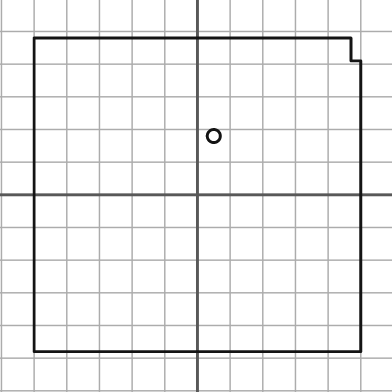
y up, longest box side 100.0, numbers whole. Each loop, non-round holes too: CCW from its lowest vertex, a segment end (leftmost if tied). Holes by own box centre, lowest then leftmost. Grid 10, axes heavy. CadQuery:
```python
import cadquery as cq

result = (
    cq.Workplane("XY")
    .moveTo(-50.0, -48.0)
    .lineTo(50.0, -48.0)
    .lineTo(50.0, 41.0)
    .lineTo(47.0, 41.0)
    .lineTo(47.0, 48.0)
    .lineTo(-50.0, 48.0)
    .close()
    .moveTo(5.0, 18.0)
    .circle(2.0)
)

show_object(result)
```